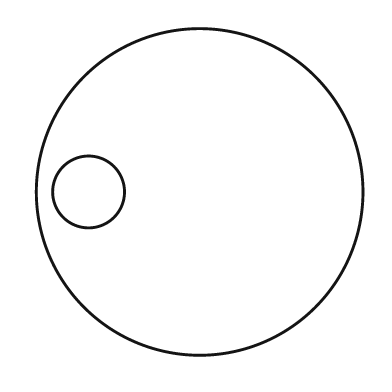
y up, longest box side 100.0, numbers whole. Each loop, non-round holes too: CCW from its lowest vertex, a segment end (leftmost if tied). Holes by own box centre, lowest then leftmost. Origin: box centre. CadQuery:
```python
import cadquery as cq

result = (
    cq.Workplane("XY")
    .moveTo(0.0, 0.0)
    .circle(50.0)
    .moveTo(-34.0, 0.0)
    .circle(11.0)
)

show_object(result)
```